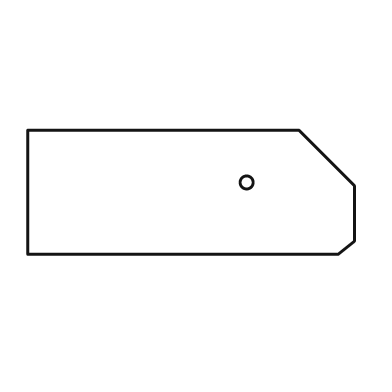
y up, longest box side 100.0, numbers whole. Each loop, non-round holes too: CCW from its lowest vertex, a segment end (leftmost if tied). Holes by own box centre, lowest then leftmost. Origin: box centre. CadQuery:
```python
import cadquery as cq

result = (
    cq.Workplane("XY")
    .moveTo(-50.0, -19.0)
    .lineTo(45.0, -19.0)
    .lineTo(50.0, -15.0)
    .lineTo(50.0, 2.0)
    .lineTo(33.0, 19.0)
    .lineTo(-50.0, 19.0)
    .close()
    .moveTo(17.0, 3.0)
    .circle(2.0)
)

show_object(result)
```